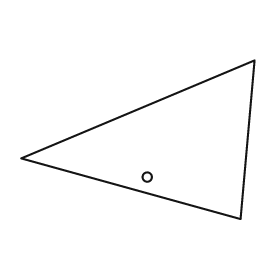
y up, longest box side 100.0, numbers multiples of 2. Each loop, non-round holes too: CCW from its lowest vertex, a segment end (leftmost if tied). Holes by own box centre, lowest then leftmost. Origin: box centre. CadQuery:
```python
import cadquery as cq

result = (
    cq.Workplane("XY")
    .moveTo(44.0, -34.0)
    .lineTo(50.0, 34.0)
    .lineTo(-50.0, -8.0)
    .close()
    .moveTo(4.0, -16.0)
    .circle(2.0)
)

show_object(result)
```